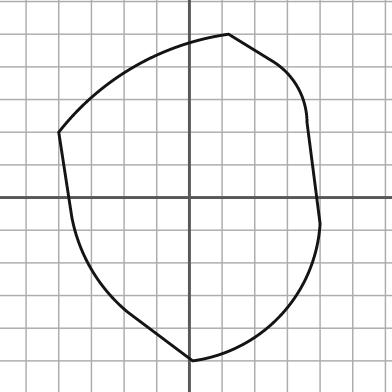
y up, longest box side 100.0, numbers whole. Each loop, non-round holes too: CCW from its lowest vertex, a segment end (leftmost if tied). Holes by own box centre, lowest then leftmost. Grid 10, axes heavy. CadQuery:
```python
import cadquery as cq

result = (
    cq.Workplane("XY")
    .moveTo(1.0, -50.0)
    .threePointArc((28.0, -36.0), (40.0, -8.0))
    .lineTo(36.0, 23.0)
    .threePointArc((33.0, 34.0), (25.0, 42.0))
    .lineTo(12.0, 50.0)
    .threePointArc((-17.0, 40.0), (-40.0, 20.0))
    .lineTo(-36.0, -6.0)
    .threePointArc((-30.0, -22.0), (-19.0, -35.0))
    .close()
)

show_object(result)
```